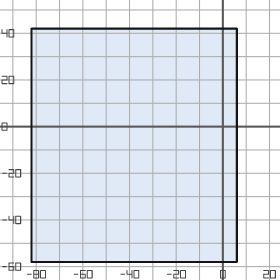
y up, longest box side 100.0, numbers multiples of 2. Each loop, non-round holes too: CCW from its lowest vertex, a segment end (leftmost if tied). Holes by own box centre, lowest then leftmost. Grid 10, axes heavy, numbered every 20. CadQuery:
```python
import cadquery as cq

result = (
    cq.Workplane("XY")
    .moveTo(-82.0, -58.0)
    .lineTo(6.0, -58.0)
    .lineTo(6.0, 42.0)
    .lineTo(-82.0, 42.0)
    .close()
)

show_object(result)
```